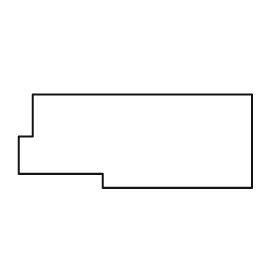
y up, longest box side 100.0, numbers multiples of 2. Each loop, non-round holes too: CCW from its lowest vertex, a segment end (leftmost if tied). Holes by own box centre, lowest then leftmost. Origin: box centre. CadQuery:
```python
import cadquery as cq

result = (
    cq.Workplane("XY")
    .moveTo(-14.0, -20.0)
    .lineTo(50.0, -20.0)
    .lineTo(50.0, 20.0)
    .lineTo(-44.0, 20.0)
    .lineTo(-44.0, 2.0)
    .lineTo(-50.0, 2.0)
    .lineTo(-50.0, -14.0)
    .lineTo(-14.0, -14.0)
    .close()
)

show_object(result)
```